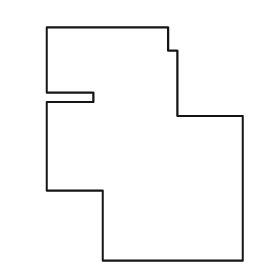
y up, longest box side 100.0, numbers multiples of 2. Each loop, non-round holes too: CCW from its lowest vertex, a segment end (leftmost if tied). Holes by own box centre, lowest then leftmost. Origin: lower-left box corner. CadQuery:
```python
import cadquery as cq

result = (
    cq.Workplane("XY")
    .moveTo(24.0, 0.0)
    .lineTo(84.0, 0.0)
    .lineTo(84.0, 62.0)
    .lineTo(56.0, 62.0)
    .lineTo(56.0, 90.0)
    .lineTo(52.0, 90.0)
    .lineTo(52.0, 100.0)
    .lineTo(0.0, 100.0)
    .lineTo(0.0, 72.0)
    .lineTo(20.0, 72.0)
    .lineTo(20.0, 68.0)
    .lineTo(0.0, 68.0)
    .lineTo(0.0, 30.0)
    .lineTo(24.0, 30.0)
    .close()
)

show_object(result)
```